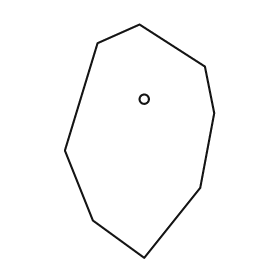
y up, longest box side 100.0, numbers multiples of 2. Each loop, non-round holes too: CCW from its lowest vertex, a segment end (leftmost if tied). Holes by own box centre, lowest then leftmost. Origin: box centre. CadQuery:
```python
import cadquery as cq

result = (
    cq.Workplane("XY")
    .moveTo(2.0, -50.0)
    .lineTo(26.0, -20.0)
    .lineTo(32.0, 12.0)
    .lineTo(28.0, 32.0)
    .lineTo(0.0, 50.0)
    .lineTo(-18.0, 42.0)
    .lineTo(-32.0, -4.0)
    .lineTo(-20.0, -34.0)
    .close()
    .moveTo(2.0, 18.0)
    .circle(2.0)
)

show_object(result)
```